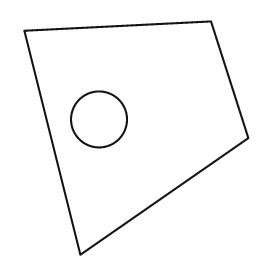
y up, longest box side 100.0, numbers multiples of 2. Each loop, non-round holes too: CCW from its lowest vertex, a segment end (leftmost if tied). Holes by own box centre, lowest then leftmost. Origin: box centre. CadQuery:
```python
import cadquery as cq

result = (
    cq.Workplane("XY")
    .moveTo(-24.0, -50.0)
    .lineTo(48.0, 0.0)
    .lineTo(32.0, 50.0)
    .lineTo(-48.0, 46.0)
    .close()
    .moveTo(-16.0, 8.0)
    .circle(12.0)
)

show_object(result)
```